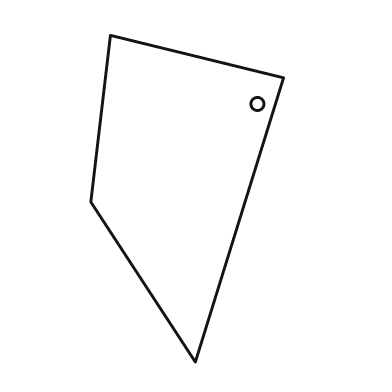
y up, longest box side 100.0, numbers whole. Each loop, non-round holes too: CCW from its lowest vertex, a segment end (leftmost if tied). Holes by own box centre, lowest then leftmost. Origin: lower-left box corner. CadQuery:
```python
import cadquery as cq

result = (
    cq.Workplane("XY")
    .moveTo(32.0, 0.0)
    .lineTo(59.0, 87.0)
    .lineTo(6.0, 100.0)
    .lineTo(0.0, 49.0)
    .close()
    .moveTo(51.0, 79.0)
    .circle(2.0)
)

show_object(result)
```